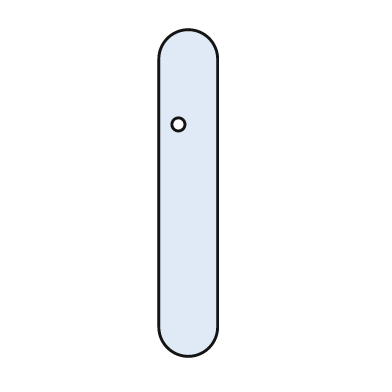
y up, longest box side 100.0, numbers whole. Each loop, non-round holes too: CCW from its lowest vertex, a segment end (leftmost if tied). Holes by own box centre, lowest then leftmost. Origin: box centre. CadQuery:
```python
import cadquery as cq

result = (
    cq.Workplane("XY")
    .moveTo(-9.0, -41.0)
    .threePointArc((0.0, -50.0), (9.0, -41.0))
    .lineTo(9.0, 41.0)
    .threePointArc((0.0, 50.0), (-9.0, 41.0))
    .close()
    .moveTo(-3.0, 21.0)
    .circle(2.0)
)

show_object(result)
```